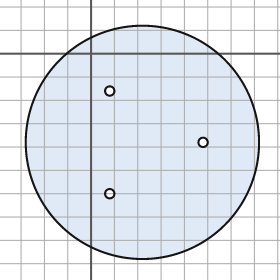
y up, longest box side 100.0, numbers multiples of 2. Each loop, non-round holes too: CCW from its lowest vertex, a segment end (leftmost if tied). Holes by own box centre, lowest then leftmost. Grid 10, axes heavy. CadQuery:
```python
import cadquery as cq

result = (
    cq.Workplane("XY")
    .moveTo(22.0, -38.0)
    .circle(50.0)
    .moveTo(8.0, -60.0)
    .circle(2.0)
    .moveTo(48.0, -38.0)
    .circle(2.0)
    .moveTo(8.0, -16.0)
    .circle(2.0)
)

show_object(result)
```